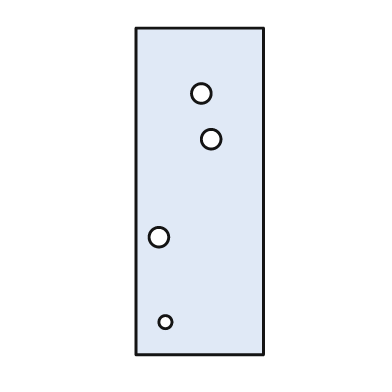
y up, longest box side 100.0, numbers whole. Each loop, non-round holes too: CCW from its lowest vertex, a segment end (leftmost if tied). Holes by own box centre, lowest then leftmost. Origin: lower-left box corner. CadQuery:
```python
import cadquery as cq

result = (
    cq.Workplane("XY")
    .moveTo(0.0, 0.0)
    .lineTo(39.0, 0.0)
    .lineTo(39.0, 100.0)
    .lineTo(0.0, 100.0)
    .close()
    .moveTo(9.0, 10.0)
    .circle(2.0)
    .moveTo(7.0, 36.0)
    .circle(3.0)
    .moveTo(23.0, 66.0)
    .circle(3.0)
    .moveTo(20.0, 80.0)
    .circle(3.0)
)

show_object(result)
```